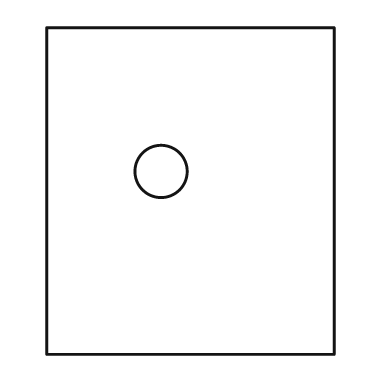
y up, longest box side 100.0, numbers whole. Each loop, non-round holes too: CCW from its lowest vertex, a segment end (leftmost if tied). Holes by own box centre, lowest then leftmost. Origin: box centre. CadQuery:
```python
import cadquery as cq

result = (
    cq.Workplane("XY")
    .moveTo(-44.0, -50.0)
    .lineTo(44.0, -50.0)
    .lineTo(44.0, 50.0)
    .lineTo(-44.0, 50.0)
    .close()
    .moveTo(-9.0, 6.0)
    .circle(8.0)
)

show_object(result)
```